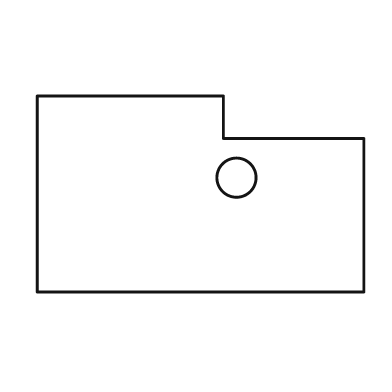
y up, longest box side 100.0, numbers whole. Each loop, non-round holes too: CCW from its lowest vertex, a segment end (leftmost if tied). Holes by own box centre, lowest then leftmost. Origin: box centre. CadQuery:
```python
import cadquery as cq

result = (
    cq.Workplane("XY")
    .moveTo(-50.0, -30.0)
    .lineTo(50.0, -30.0)
    .lineTo(50.0, 17.0)
    .lineTo(7.0, 17.0)
    .lineTo(7.0, 30.0)
    .lineTo(-50.0, 30.0)
    .close()
    .moveTo(11.0, 5.0)
    .circle(6.0)
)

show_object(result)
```